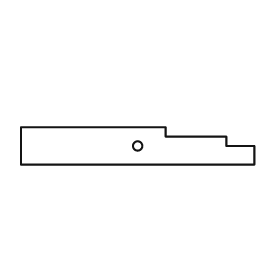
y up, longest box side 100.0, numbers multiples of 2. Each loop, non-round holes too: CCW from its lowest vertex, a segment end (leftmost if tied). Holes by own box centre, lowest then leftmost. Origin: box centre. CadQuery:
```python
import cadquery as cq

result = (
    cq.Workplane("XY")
    .moveTo(-50.0, -8.0)
    .lineTo(50.0, -8.0)
    .lineTo(50.0, 0.0)
    .lineTo(38.0, 0.0)
    .lineTo(38.0, 4.0)
    .lineTo(12.0, 4.0)
    .lineTo(12.0, 8.0)
    .lineTo(-50.0, 8.0)
    .close()
    .moveTo(0.0, 0.0)
    .circle(2.0)
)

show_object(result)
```